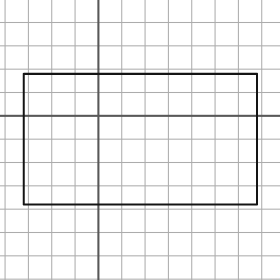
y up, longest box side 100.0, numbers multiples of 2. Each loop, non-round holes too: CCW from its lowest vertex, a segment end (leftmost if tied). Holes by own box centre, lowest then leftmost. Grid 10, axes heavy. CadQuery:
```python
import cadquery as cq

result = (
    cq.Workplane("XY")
    .moveTo(-32.0, -38.0)
    .lineTo(68.0, -38.0)
    .lineTo(68.0, 18.0)
    .lineTo(-32.0, 18.0)
    .close()
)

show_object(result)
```